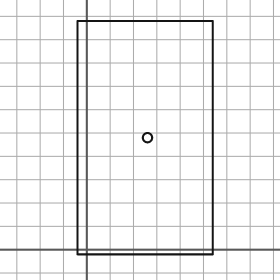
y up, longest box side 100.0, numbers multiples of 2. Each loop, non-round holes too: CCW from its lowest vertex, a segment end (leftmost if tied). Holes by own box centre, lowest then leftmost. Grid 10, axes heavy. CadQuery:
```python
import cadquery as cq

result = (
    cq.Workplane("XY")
    .moveTo(-4.0, -2.0)
    .lineTo(54.0, -2.0)
    .lineTo(54.0, 98.0)
    .lineTo(-4.0, 98.0)
    .close()
    .moveTo(26.0, 48.0)
    .circle(2.0)
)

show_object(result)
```